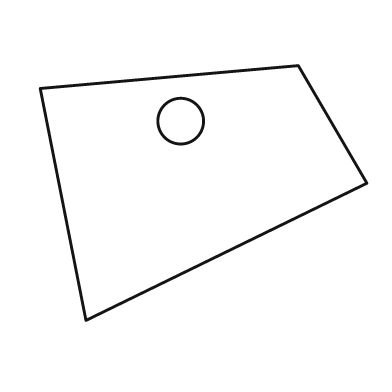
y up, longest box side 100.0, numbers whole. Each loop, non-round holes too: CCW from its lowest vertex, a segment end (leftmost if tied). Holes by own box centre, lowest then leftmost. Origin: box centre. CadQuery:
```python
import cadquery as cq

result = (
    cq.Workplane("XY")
    .moveTo(-36.0, -39.0)
    .lineTo(50.0, 3.0)
    .lineTo(29.0, 39.0)
    .lineTo(-50.0, 32.0)
    .close()
    .moveTo(-7.0, 22.0)
    .circle(7.0)
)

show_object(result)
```